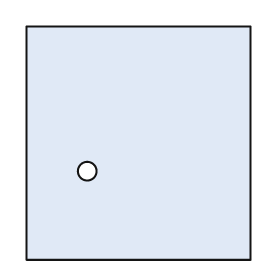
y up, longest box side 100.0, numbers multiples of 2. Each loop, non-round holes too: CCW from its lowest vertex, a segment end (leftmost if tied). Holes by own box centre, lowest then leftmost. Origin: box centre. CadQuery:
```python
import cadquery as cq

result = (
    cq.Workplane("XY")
    .moveTo(-48.0, -50.0)
    .lineTo(48.0, -50.0)
    .lineTo(48.0, 50.0)
    .lineTo(-48.0, 50.0)
    .close()
    .moveTo(-22.0, -12.0)
    .circle(4.0)
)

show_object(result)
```